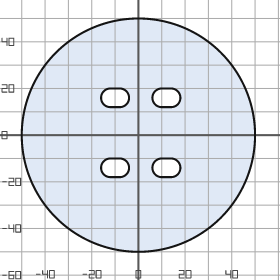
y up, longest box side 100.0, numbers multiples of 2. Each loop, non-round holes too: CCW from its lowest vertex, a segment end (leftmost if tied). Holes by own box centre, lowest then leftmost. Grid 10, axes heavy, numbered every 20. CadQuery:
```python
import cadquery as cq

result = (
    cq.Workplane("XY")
    .moveTo(0.0, 0.0)
    .circle(50.0)
    .moveTo(-12.0, -18.0)
    .lineTo(-8.0, -18.0)
    .threePointArc((-4.0, -14.0), (-8.0, -10.0))
    .lineTo(-12.0, -10.0)
    .threePointArc((-16.0, -14.0), (-12.0, -18.0))
    .close()
    .moveTo(10.0, -18.0)
    .lineTo(14.0, -18.0)
    .threePointArc((18.0, -14.0), (14.0, -10.0))
    .lineTo(10.0, -10.0)
    .threePointArc((6.0, -14.0), (10.0, -18.0))
    .close()
    .moveTo(-12.0, 12.0)
    .lineTo(-8.0, 12.0)
    .threePointArc((-4.0, 16.0), (-8.0, 20.0))
    .lineTo(-12.0, 20.0)
    .threePointArc((-16.0, 16.0), (-12.0, 12.0))
    .close()
    .moveTo(10.0, 12.0)
    .lineTo(14.0, 12.0)
    .threePointArc((18.0, 16.0), (14.0, 20.0))
    .lineTo(10.0, 20.0)
    .threePointArc((6.0, 16.0), (10.0, 12.0))
    .close()
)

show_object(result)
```